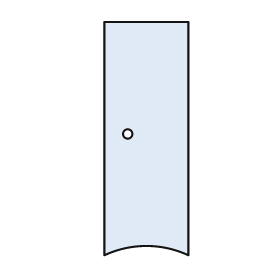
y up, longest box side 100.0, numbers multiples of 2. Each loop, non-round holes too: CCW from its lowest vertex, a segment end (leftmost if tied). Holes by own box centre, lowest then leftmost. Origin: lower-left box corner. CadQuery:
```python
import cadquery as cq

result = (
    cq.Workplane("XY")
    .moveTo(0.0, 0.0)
    .threePointArc((18.0, 4.0), (36.0, 0.0))
    .lineTo(36.0, 100.0)
    .lineTo(0.0, 100.0)
    .close()
    .moveTo(10.0, 52.0)
    .circle(2.0)
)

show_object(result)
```